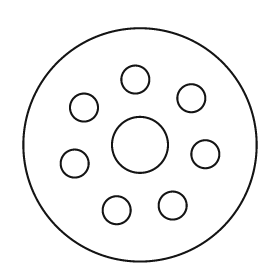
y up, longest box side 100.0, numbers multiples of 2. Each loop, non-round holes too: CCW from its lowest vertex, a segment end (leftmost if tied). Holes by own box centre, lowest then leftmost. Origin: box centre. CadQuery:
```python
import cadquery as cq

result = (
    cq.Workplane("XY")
    .moveTo(0.0, 0.0)
    .circle(50.0)
    .moveTo(-10.0, -28.0)
    .circle(6.0)
    .moveTo(14.0, -26.0)
    .circle(6.0)
    .moveTo(-28.0, -8.0)
    .circle(6.0)
    .moveTo(28.0, -4.0)
    .circle(6.0)
    .moveTo(0.0, 0.0)
    .circle(12.0)
    .moveTo(-24.0, 16.0)
    .circle(6.0)
    .moveTo(22.0, 20.0)
    .circle(6.0)
    .moveTo(-2.0, 28.0)
    .circle(6.0)
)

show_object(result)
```